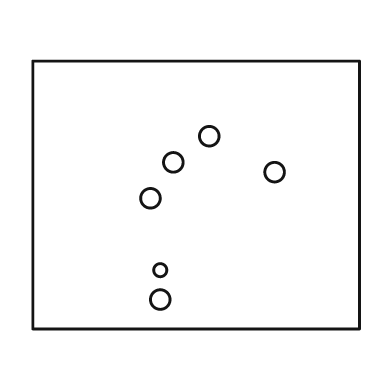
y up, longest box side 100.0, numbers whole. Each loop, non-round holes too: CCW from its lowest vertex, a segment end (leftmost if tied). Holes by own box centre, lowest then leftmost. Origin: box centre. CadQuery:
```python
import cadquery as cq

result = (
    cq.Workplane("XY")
    .moveTo(-50.0, -41.0)
    .lineTo(50.0, -41.0)
    .lineTo(50.0, 41.0)
    .lineTo(-50.0, 41.0)
    .close()
    .moveTo(-11.0, -32.0)
    .circle(3.0)
    .moveTo(-11.0, -23.0)
    .circle(2.0)
    .moveTo(-14.0, -1.0)
    .circle(3.0)
    .moveTo(24.0, 7.0)
    .circle(3.0)
    .moveTo(-7.0, 10.0)
    .circle(3.0)
    .moveTo(4.0, 18.0)
    .circle(3.0)
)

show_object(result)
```